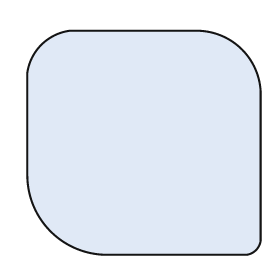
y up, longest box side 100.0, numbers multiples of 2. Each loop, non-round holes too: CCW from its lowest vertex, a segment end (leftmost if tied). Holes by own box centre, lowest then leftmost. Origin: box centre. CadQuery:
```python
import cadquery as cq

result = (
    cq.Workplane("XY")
    .moveTo(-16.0, -48.0)
    .lineTo(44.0, -48.0)
    .threePointArc((48.0, -46.0), (50.0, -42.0))
    .lineTo(50.0, 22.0)
    .threePointArc((42.0, 40.0), (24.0, 48.0))
    .lineTo(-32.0, 48.0)
    .threePointArc((-44.0, 42.0), (-50.0, 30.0))
    .lineTo(-50.0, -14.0)
    .threePointArc((-40.0, -38.0), (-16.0, -48.0))
    .close()
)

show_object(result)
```